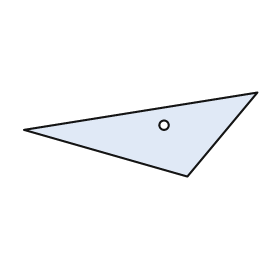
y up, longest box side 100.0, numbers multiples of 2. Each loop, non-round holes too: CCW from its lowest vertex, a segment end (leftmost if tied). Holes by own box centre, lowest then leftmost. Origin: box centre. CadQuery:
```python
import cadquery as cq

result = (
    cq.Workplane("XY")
    .moveTo(20.0, -18.0)
    .lineTo(50.0, 18.0)
    .lineTo(-50.0, 2.0)
    .close()
    .moveTo(10.0, 4.0)
    .circle(2.0)
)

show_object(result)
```